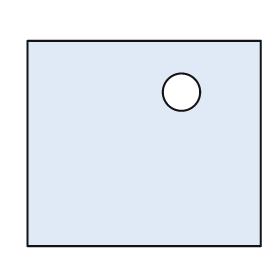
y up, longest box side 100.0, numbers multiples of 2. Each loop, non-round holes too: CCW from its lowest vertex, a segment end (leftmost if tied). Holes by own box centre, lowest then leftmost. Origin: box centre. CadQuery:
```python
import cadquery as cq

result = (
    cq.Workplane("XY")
    .moveTo(-50.0, -44.0)
    .lineTo(50.0, -44.0)
    .lineTo(50.0, 44.0)
    .lineTo(-50.0, 44.0)
    .close()
    .moveTo(16.0, 22.0)
    .circle(8.0)
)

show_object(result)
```